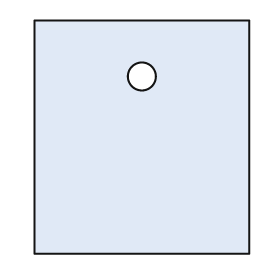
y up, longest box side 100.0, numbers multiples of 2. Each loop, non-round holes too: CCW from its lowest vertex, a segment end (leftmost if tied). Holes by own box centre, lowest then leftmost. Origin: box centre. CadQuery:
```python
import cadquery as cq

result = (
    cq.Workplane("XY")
    .moveTo(-46.0, -50.0)
    .lineTo(46.0, -50.0)
    .lineTo(46.0, 50.0)
    .lineTo(-46.0, 50.0)
    .close()
    .moveTo(0.0, 26.0)
    .circle(6.0)
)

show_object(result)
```